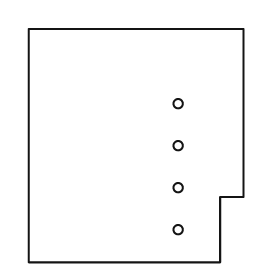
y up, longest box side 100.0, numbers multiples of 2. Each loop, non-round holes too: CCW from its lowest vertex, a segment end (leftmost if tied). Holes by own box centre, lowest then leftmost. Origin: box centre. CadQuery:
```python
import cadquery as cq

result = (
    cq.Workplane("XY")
    .moveTo(-46.0, -50.0)
    .lineTo(36.0, -50.0)
    .lineTo(36.0, -22.0)
    .lineTo(46.0, -22.0)
    .lineTo(46.0, 50.0)
    .lineTo(-46.0, 50.0)
    .close()
    .moveTo(18.0, -36.0)
    .circle(2.0)
    .moveTo(18.0, -18.0)
    .circle(2.0)
    .moveTo(18.0, 0.0)
    .circle(2.0)
    .moveTo(18.0, 18.0)
    .circle(2.0)
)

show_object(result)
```